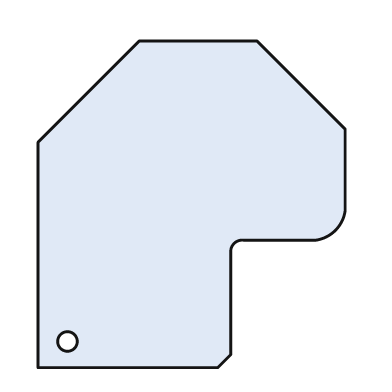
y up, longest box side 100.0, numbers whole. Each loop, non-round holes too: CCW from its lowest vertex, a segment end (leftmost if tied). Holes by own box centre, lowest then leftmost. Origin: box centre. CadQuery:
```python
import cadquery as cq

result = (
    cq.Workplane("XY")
    .moveTo(-47.0, -50.0)
    .lineTo(8.0, -50.0)
    .lineTo(12.0, -46.0)
    .lineTo(12.0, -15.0)
    .threePointArc((13.0, -12.0), (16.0, -11.0))
    .lineTo(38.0, -11.0)
    .threePointArc((44.0, -8.0), (47.0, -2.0))
    .lineTo(47.0, 23.0)
    .lineTo(20.0, 50.0)
    .lineTo(-16.0, 50.0)
    .lineTo(-47.0, 19.0)
    .close()
    .moveTo(-38.0, -42.0)
    .circle(3.0)
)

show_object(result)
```